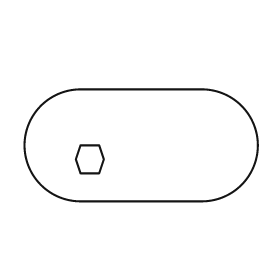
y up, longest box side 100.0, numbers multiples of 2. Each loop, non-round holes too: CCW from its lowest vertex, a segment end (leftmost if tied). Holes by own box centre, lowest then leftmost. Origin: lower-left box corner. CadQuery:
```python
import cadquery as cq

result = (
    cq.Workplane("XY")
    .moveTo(24.0, 0.0)
    .lineTo(76.0, 0.0)
    .threePointArc((100.0, 24.0), (76.0, 48.0))
    .lineTo(24.0, 48.0)
    .threePointArc((0.0, 24.0), (24.0, 0.0))
    .close()
    .moveTo(24.0, 12.0)
    .lineTo(32.0, 12.0)
    .lineTo(34.0, 18.0)
    .lineTo(32.0, 24.0)
    .lineTo(24.0, 24.0)
    .lineTo(22.0, 18.0)
    .close()
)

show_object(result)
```